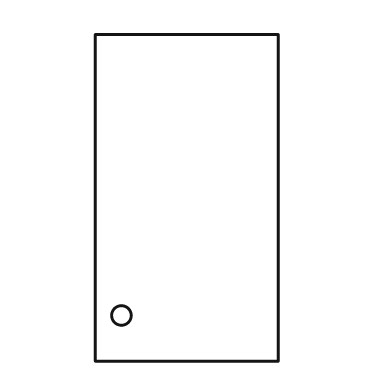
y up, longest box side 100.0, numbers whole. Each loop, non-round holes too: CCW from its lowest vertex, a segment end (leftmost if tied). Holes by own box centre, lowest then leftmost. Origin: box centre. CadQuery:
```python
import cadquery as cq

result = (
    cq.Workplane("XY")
    .moveTo(-28.0, -50.0)
    .lineTo(28.0, -50.0)
    .lineTo(28.0, 50.0)
    .lineTo(-28.0, 50.0)
    .close()
    .moveTo(-20.0, -36.0)
    .circle(3.0)
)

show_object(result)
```